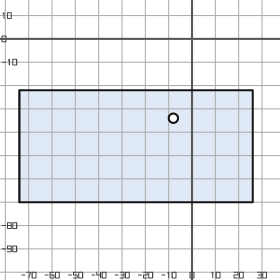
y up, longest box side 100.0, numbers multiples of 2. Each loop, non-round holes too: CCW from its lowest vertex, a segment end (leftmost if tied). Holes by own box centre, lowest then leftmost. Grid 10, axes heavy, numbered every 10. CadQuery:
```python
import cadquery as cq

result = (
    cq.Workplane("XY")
    .moveTo(-74.0, -70.0)
    .lineTo(26.0, -70.0)
    .lineTo(26.0, -22.0)
    .lineTo(-74.0, -22.0)
    .close()
    .moveTo(-8.0, -34.0)
    .circle(2.0)
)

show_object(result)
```